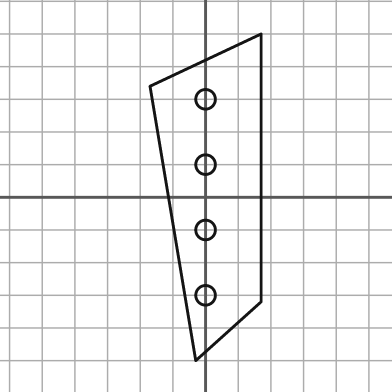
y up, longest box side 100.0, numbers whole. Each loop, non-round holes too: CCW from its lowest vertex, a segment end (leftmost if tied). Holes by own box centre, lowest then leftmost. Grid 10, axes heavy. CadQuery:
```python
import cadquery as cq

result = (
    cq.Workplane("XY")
    .moveTo(-3.0, -50.0)
    .lineTo(17.0, -32.0)
    .lineTo(17.0, 50.0)
    .lineTo(-17.0, 34.0)
    .close()
    .moveTo(0.0, -30.0)
    .circle(3.0)
    .moveTo(0.0, -10.0)
    .circle(3.0)
    .moveTo(0.0, 10.0)
    .circle(3.0)
    .moveTo(0.0, 30.0)
    .circle(3.0)
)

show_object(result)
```